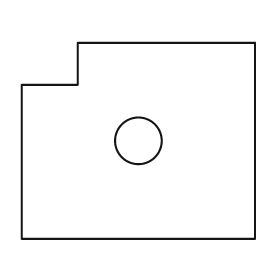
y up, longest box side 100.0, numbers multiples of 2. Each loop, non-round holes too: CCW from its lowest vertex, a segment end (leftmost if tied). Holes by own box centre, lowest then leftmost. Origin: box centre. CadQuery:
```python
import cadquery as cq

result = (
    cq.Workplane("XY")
    .moveTo(-50.0, -42.0)
    .lineTo(50.0, -42.0)
    .lineTo(50.0, 42.0)
    .lineTo(-26.0, 42.0)
    .lineTo(-26.0, 24.0)
    .lineTo(-50.0, 24.0)
    .close()
    .moveTo(0.0, 0.0)
    .circle(10.0)
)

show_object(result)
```